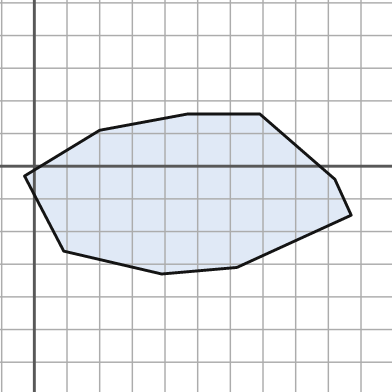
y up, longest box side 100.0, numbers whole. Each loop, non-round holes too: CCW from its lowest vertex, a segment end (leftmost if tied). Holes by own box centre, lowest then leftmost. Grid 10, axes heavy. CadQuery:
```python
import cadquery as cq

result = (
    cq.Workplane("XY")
    .moveTo(39.0, -33.0)
    .lineTo(62.0, -31.0)
    .lineTo(97.0, -15.0)
    .lineTo(92.0, -4.0)
    .lineTo(69.0, 16.0)
    .lineTo(47.0, 16.0)
    .lineTo(20.0, 11.0)
    .lineTo(-3.0, -3.0)
    .lineTo(9.0, -26.0)
    .close()
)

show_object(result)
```